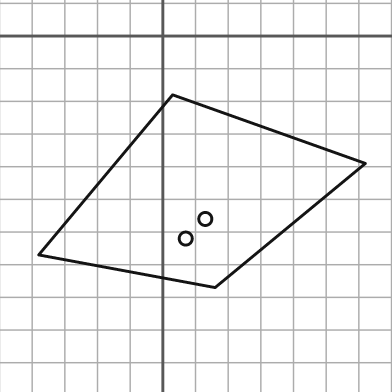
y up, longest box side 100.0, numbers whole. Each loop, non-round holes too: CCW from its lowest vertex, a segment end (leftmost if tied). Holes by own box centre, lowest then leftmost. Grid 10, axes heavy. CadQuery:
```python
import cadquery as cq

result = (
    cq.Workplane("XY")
    .moveTo(16.0, -77.0)
    .lineTo(62.0, -39.0)
    .lineTo(3.0, -18.0)
    .lineTo(-38.0, -67.0)
    .close()
    .moveTo(7.0, -62.0)
    .circle(2.0)
    .moveTo(13.0, -56.0)
    .circle(2.0)
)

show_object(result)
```